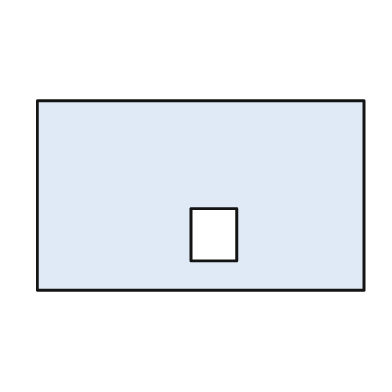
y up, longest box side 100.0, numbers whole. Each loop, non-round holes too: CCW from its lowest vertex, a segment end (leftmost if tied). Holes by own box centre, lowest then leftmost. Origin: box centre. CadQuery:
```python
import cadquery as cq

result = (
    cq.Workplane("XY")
    .moveTo(-50.0, -29.0)
    .lineTo(50.0, -29.0)
    .lineTo(50.0, 29.0)
    .lineTo(-50.0, 29.0)
    .close()
    .moveTo(-3.0, -20.0)
    .lineTo(11.0, -20.0)
    .lineTo(11.0, -4.0)
    .lineTo(-3.0, -4.0)
    .close()
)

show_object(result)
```